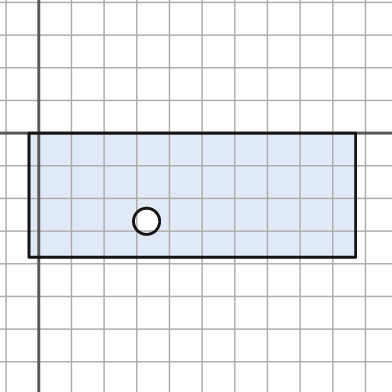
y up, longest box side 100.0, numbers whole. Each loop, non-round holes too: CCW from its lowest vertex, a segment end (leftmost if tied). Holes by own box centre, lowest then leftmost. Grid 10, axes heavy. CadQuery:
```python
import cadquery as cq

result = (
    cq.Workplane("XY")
    .moveTo(-3.0, -38.0)
    .lineTo(97.0, -38.0)
    .lineTo(97.0, 0.0)
    .lineTo(-3.0, 0.0)
    .close()
    .moveTo(33.0, -27.0)
    .circle(4.0)
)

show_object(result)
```